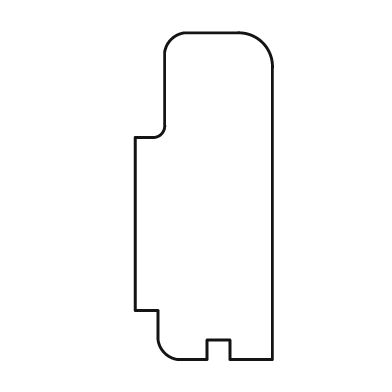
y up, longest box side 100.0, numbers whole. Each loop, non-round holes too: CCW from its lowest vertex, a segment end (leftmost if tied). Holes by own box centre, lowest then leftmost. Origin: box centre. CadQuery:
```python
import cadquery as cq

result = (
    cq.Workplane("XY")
    .moveTo(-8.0, -50.0)
    .lineTo(1.0, -50.0)
    .lineTo(1.0, -44.0)
    .lineTo(8.0, -44.0)
    .lineTo(8.0, -50.0)
    .lineTo(21.0, -50.0)
    .lineTo(21.0, 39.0)
    .threePointArc((18.0, 47.0), (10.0, 50.0))
    .lineTo(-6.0, 50.0)
    .threePointArc((-10.0, 48.0), (-12.0, 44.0))
    .lineTo(-12.0, 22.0)
    .threePointArc((-13.0, 19.0), (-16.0, 18.0))
    .lineTo(-21.0, 18.0)
    .lineTo(-21.0, -35.0)
    .lineTo(-14.0, -35.0)
    .lineTo(-14.0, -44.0)
    .threePointArc((-12.0, -48.0), (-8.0, -50.0))
    .close()
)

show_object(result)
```